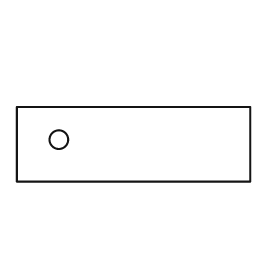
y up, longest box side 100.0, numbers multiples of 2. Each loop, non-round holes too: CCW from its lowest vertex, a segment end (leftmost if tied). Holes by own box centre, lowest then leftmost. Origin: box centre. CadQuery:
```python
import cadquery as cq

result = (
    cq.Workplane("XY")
    .moveTo(-50.0, -16.0)
    .lineTo(50.0, -16.0)
    .lineTo(50.0, 16.0)
    .lineTo(-50.0, 16.0)
    .close()
    .moveTo(-32.0, 2.0)
    .circle(4.0)
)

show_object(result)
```